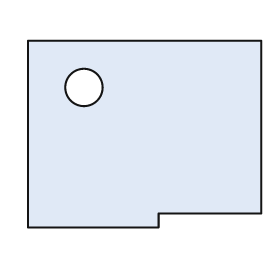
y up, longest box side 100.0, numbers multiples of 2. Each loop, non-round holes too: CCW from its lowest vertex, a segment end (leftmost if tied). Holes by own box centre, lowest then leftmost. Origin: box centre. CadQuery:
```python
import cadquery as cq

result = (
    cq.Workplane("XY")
    .moveTo(-50.0, -40.0)
    .lineTo(6.0, -40.0)
    .lineTo(6.0, -34.0)
    .lineTo(50.0, -34.0)
    .lineTo(50.0, 40.0)
    .lineTo(-50.0, 40.0)
    .close()
    .moveTo(-26.0, 20.0)
    .circle(8.0)
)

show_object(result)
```